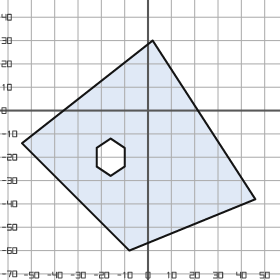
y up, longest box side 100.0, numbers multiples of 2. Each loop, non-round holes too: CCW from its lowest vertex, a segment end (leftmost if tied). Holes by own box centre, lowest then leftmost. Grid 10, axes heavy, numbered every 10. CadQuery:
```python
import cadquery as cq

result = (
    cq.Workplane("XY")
    .moveTo(-8.0, -60.0)
    .lineTo(46.0, -38.0)
    .lineTo(2.0, 30.0)
    .lineTo(-54.0, -14.0)
    .close()
    .moveTo(-16.0, -28.0)
    .lineTo(-10.0, -24.0)
    .lineTo(-10.0, -16.0)
    .lineTo(-16.0, -12.0)
    .lineTo(-22.0, -16.0)
    .lineTo(-22.0, -24.0)
    .close()
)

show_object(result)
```